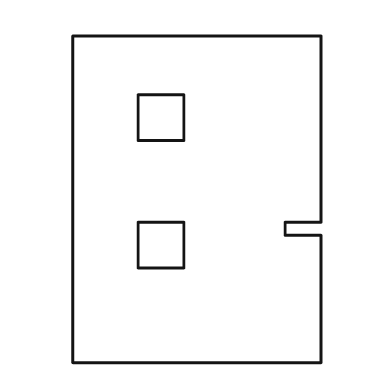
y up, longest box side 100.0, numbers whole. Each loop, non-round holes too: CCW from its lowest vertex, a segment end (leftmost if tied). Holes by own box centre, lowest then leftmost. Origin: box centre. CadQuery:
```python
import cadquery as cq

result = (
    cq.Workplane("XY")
    .moveTo(-38.0, -50.0)
    .lineTo(38.0, -50.0)
    .lineTo(38.0, -11.0)
    .lineTo(27.0, -11.0)
    .lineTo(27.0, -7.0)
    .lineTo(38.0, -7.0)
    .lineTo(38.0, 50.0)
    .lineTo(-38.0, 50.0)
    .close()
    .moveTo(-18.0, -21.0)
    .lineTo(-4.0, -21.0)
    .lineTo(-4.0, -7.0)
    .lineTo(-18.0, -7.0)
    .close()
    .moveTo(-18.0, 18.0)
    .lineTo(-4.0, 18.0)
    .lineTo(-4.0, 32.0)
    .lineTo(-18.0, 32.0)
    .close()
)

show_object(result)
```